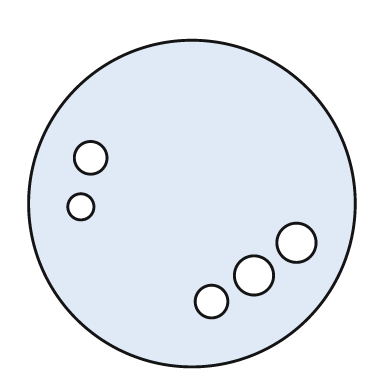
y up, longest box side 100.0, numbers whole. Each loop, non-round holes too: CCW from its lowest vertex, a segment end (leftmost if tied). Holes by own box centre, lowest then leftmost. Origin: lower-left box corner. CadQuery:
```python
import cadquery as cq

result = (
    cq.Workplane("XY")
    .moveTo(50.0, 50.0)
    .circle(50.0)
    .moveTo(56.0, 20.0)
    .circle(5.0)
    .moveTo(69.0, 28.0)
    .circle(6.0)
    .moveTo(82.0, 38.0)
    .circle(6.0)
    .moveTo(16.0, 49.0)
    .circle(4.0)
    .moveTo(19.0, 64.0)
    .circle(5.0)
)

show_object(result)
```